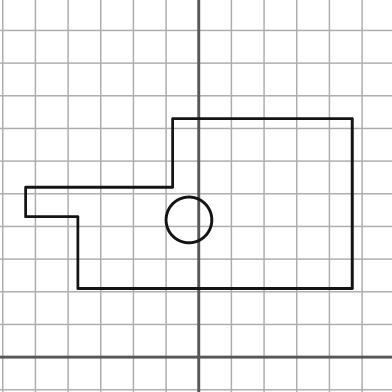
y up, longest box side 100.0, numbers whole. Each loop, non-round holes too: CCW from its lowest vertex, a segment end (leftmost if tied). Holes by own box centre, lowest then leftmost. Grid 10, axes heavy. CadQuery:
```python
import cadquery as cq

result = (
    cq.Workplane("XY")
    .moveTo(-37.0, 21.0)
    .lineTo(47.0, 21.0)
    .lineTo(47.0, 73.0)
    .lineTo(-8.0, 73.0)
    .lineTo(-8.0, 52.0)
    .lineTo(-53.0, 52.0)
    .lineTo(-53.0, 43.0)
    .lineTo(-37.0, 43.0)
    .close()
    .moveTo(-3.0, 42.0)
    .circle(7.0)
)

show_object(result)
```